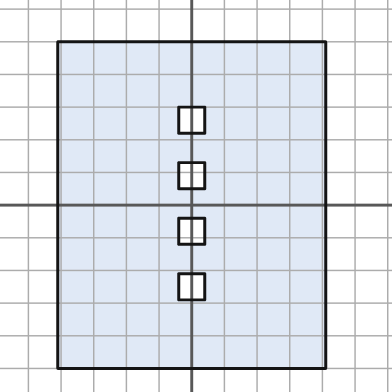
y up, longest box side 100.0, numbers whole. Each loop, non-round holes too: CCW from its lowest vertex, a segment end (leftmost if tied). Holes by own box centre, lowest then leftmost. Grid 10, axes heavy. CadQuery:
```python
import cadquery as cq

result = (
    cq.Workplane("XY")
    .moveTo(-41.0, -50.0)
    .lineTo(41.0, -50.0)
    .lineTo(41.0, 50.0)
    .lineTo(-41.0, 50.0)
    .close()
    .moveTo(-4.0, -29.0)
    .lineTo(4.0, -29.0)
    .lineTo(4.0, -21.0)
    .lineTo(-4.0, -21.0)
    .close()
    .moveTo(-4.0, -12.0)
    .lineTo(4.0, -12.0)
    .lineTo(4.0, -4.0)
    .lineTo(-4.0, -4.0)
    .close()
    .moveTo(-4.0, 5.0)
    .lineTo(4.0, 5.0)
    .lineTo(4.0, 13.0)
    .lineTo(-4.0, 13.0)
    .close()
    .moveTo(-4.0, 22.0)
    .lineTo(4.0, 22.0)
    .lineTo(4.0, 30.0)
    .lineTo(-4.0, 30.0)
    .close()
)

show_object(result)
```